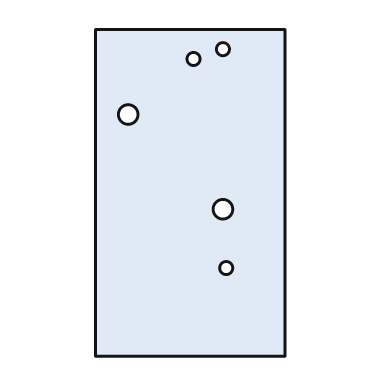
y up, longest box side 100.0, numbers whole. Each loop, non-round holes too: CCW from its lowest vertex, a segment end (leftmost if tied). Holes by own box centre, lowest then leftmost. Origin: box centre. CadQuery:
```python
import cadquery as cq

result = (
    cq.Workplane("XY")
    .moveTo(-29.0, -50.0)
    .lineTo(29.0, -50.0)
    .lineTo(29.0, 50.0)
    .lineTo(-29.0, 50.0)
    .close()
    .moveTo(11.0, -23.0)
    .circle(2.0)
    .moveTo(10.0, -5.0)
    .circle(3.0)
    .moveTo(-19.0, 24.0)
    .circle(3.0)
    .moveTo(1.0, 41.0)
    .circle(2.0)
    .moveTo(10.0, 44.0)
    .circle(2.0)
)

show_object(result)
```